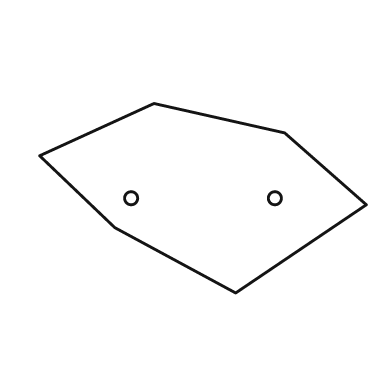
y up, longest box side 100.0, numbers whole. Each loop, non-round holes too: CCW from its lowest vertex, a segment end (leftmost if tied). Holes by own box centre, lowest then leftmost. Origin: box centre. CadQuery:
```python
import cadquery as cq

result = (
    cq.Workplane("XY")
    .moveTo(10.0, -29.0)
    .lineTo(50.0, -2.0)
    .lineTo(25.0, 20.0)
    .lineTo(-15.0, 29.0)
    .lineTo(-50.0, 13.0)
    .lineTo(-27.0, -9.0)
    .close()
    .moveTo(-22.0, 0.0)
    .circle(2.0)
    .moveTo(22.0, 0.0)
    .circle(2.0)
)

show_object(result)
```